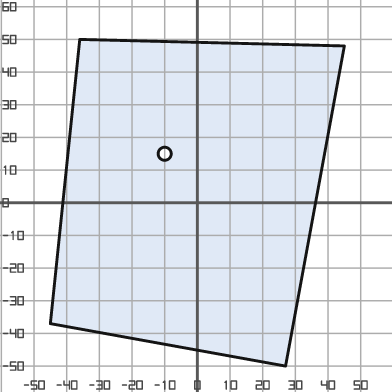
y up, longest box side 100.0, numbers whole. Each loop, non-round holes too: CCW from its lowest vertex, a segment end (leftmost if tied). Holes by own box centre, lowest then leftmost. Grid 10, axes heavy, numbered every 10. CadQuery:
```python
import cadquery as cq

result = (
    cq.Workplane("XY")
    .moveTo(27.0, -50.0)
    .lineTo(45.0, 48.0)
    .lineTo(-36.0, 50.0)
    .lineTo(-45.0, -37.0)
    .close()
    .moveTo(-10.0, 15.0)
    .circle(2.0)
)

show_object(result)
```